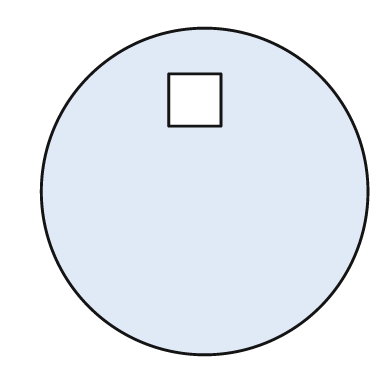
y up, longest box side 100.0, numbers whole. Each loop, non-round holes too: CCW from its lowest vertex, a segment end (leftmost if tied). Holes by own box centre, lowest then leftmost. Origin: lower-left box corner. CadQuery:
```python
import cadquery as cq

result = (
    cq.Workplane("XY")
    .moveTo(50.0, 50.0)
    .circle(50.0)
    .moveTo(39.0, 70.0)
    .lineTo(55.0, 70.0)
    .lineTo(55.0, 86.0)
    .lineTo(39.0, 86.0)
    .close()
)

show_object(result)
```